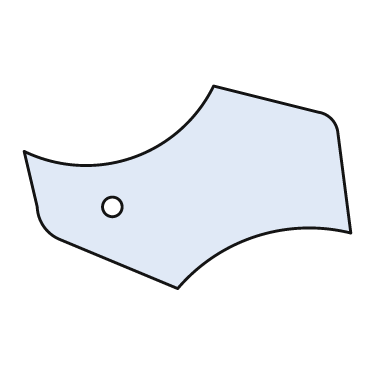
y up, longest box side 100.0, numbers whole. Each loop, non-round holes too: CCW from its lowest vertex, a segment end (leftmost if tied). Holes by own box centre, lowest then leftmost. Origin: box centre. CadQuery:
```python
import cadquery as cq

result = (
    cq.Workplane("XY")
    .moveTo(-3.0, -31.0)
    .threePointArc((21.0, -15.0), (50.0, -14.0))
    .lineTo(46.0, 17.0)
    .threePointArc((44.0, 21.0), (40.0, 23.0))
    .lineTo(8.0, 31.0)
    .threePointArc((-17.0, 9.0), (-50.0, 11.0))
    .lineTo(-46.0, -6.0)
    .threePointArc((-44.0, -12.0), (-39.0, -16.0))
    .close()
    .moveTo(-23.0, -6.0)
    .circle(3.0)
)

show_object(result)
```